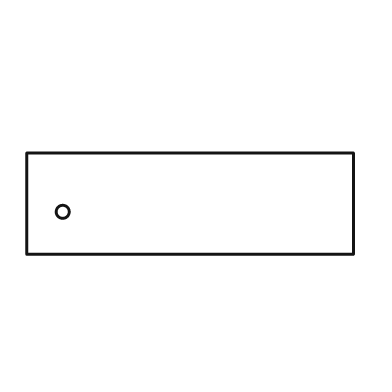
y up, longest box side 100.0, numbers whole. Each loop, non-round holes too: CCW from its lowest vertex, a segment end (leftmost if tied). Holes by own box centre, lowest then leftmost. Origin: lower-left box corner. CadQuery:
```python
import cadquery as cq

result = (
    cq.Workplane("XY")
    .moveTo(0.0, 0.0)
    .lineTo(100.0, 0.0)
    .lineTo(100.0, 31.0)
    .lineTo(0.0, 31.0)
    .close()
    .moveTo(11.0, 13.0)
    .circle(2.0)
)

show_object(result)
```